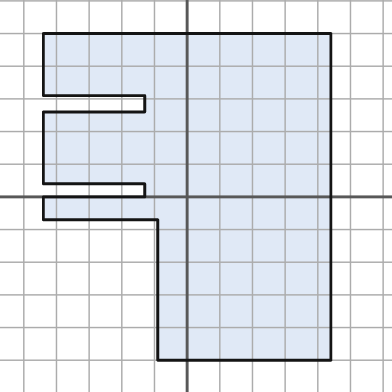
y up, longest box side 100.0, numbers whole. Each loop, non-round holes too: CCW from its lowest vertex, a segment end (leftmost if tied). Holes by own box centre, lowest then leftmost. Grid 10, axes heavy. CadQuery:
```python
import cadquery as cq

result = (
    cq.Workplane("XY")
    .moveTo(-9.0, -50.0)
    .lineTo(44.0, -50.0)
    .lineTo(44.0, 50.0)
    .lineTo(-44.0, 50.0)
    .lineTo(-44.0, 31.0)
    .lineTo(-13.0, 31.0)
    .lineTo(-13.0, 26.0)
    .lineTo(-44.0, 26.0)
    .lineTo(-44.0, 4.0)
    .lineTo(-13.0, 4.0)
    .lineTo(-13.0, 0.0)
    .lineTo(-44.0, 0.0)
    .lineTo(-44.0, -7.0)
    .lineTo(-9.0, -7.0)
    .close()
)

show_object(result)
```